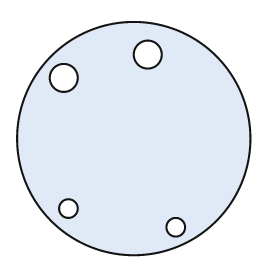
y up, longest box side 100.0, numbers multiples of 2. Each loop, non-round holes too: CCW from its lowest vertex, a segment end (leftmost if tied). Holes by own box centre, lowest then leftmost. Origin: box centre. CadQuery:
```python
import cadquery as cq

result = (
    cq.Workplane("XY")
    .moveTo(0.0, 0.0)
    .circle(50.0)
    .moveTo(18.0, -38.0)
    .circle(4.0)
    .moveTo(-28.0, -30.0)
    .circle(4.0)
    .moveTo(-30.0, 26.0)
    .circle(6.0)
    .moveTo(6.0, 36.0)
    .circle(6.0)
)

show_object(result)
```